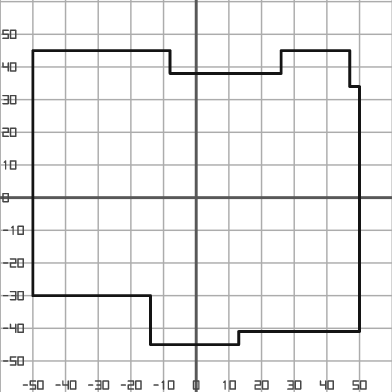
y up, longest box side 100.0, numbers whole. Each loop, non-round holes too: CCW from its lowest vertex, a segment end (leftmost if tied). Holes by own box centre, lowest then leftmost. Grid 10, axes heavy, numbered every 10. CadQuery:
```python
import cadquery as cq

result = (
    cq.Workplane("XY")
    .moveTo(-14.0, -45.0)
    .lineTo(13.0, -45.0)
    .lineTo(13.0, -41.0)
    .lineTo(50.0, -41.0)
    .lineTo(50.0, 34.0)
    .lineTo(47.0, 34.0)
    .lineTo(47.0, 45.0)
    .lineTo(26.0, 45.0)
    .lineTo(26.0, 38.0)
    .lineTo(-8.0, 38.0)
    .lineTo(-8.0, 45.0)
    .lineTo(-50.0, 45.0)
    .lineTo(-50.0, -30.0)
    .lineTo(-14.0, -30.0)
    .close()
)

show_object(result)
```